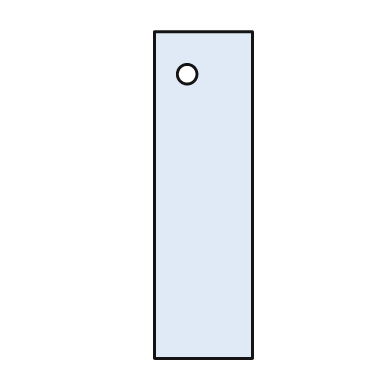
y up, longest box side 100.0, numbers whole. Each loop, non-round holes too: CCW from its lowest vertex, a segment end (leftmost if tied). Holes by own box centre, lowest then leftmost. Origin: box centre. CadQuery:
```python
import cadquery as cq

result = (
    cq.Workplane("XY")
    .moveTo(-15.0, -50.0)
    .lineTo(15.0, -50.0)
    .lineTo(15.0, 50.0)
    .lineTo(-15.0, 50.0)
    .close()
    .moveTo(-5.0, 37.0)
    .circle(3.0)
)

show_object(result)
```